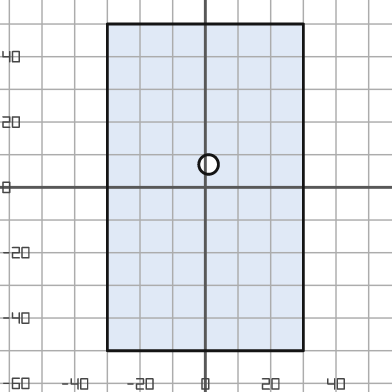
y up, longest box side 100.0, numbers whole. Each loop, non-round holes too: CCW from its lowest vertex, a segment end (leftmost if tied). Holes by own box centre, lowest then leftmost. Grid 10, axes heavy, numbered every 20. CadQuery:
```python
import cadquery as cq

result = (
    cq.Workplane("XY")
    .moveTo(-30.0, -50.0)
    .lineTo(30.0, -50.0)
    .lineTo(30.0, 50.0)
    .lineTo(-30.0, 50.0)
    .close()
    .moveTo(1.0, 7.0)
    .circle(3.0)
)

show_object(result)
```